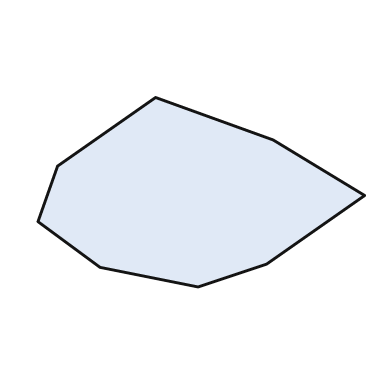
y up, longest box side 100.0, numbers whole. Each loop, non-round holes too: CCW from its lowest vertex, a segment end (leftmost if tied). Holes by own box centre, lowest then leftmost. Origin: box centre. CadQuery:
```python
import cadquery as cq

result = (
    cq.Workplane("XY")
    .moveTo(-1.0, -29.0)
    .lineTo(20.0, -22.0)
    .lineTo(50.0, -1.0)
    .lineTo(22.0, 16.0)
    .lineTo(-14.0, 29.0)
    .lineTo(-44.0, 8.0)
    .lineTo(-50.0, -9.0)
    .lineTo(-31.0, -23.0)
    .close()
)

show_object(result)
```